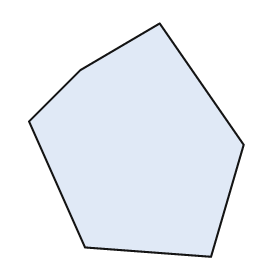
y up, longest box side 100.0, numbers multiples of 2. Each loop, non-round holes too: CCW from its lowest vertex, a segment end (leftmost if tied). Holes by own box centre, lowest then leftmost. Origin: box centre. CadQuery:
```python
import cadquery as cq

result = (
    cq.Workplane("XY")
    .moveTo(32.0, -50.0)
    .lineTo(46.0, -2.0)
    .lineTo(10.0, 50.0)
    .lineTo(-24.0, 30.0)
    .lineTo(-46.0, 8.0)
    .lineTo(-22.0, -46.0)
    .close()
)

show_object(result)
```